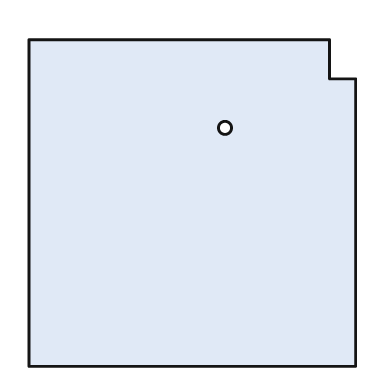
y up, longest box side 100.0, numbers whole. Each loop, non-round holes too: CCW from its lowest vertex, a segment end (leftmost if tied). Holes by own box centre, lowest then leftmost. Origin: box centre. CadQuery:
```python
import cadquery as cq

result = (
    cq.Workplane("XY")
    .moveTo(-50.0, -50.0)
    .lineTo(50.0, -50.0)
    .lineTo(50.0, 38.0)
    .lineTo(42.0, 38.0)
    .lineTo(42.0, 50.0)
    .lineTo(-50.0, 50.0)
    .close()
    .moveTo(10.0, 23.0)
    .circle(2.0)
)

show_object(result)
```